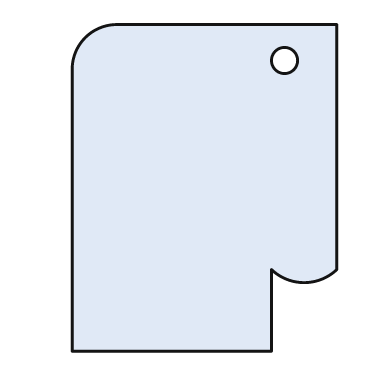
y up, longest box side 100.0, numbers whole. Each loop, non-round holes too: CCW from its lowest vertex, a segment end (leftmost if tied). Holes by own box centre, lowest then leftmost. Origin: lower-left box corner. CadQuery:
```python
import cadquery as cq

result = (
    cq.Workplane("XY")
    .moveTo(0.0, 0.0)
    .lineTo(61.0, 0.0)
    .lineTo(61.0, 25.0)
    .threePointArc((71.0, 21.0), (81.0, 25.0))
    .lineTo(81.0, 100.0)
    .lineTo(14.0, 100.0)
    .threePointArc((4.0, 96.0), (0.0, 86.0))
    .close()
    .moveTo(65.0, 89.0)
    .circle(4.0)
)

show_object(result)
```